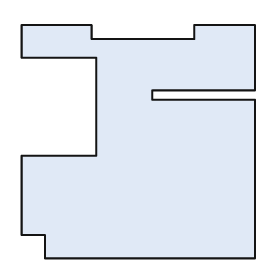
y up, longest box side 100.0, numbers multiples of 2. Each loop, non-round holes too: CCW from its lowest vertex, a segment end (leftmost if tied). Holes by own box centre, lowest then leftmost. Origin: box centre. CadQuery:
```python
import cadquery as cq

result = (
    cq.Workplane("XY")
    .moveTo(-40.0, -50.0)
    .lineTo(50.0, -50.0)
    .lineTo(50.0, 18.0)
    .lineTo(6.0, 18.0)
    .lineTo(6.0, 22.0)
    .lineTo(50.0, 22.0)
    .lineTo(50.0, 50.0)
    .lineTo(24.0, 50.0)
    .lineTo(24.0, 44.0)
    .lineTo(-20.0, 44.0)
    .lineTo(-20.0, 50.0)
    .lineTo(-50.0, 50.0)
    .lineTo(-50.0, 36.0)
    .lineTo(-18.0, 36.0)
    .lineTo(-18.0, -6.0)
    .lineTo(-50.0, -6.0)
    .lineTo(-50.0, -40.0)
    .lineTo(-40.0, -40.0)
    .close()
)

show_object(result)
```